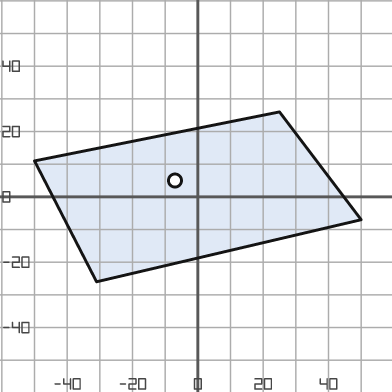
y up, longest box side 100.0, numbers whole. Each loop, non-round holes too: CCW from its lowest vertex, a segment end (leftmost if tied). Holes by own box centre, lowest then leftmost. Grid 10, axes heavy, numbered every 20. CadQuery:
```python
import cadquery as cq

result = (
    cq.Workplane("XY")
    .moveTo(-31.0, -26.0)
    .lineTo(50.0, -7.0)
    .lineTo(25.0, 26.0)
    .lineTo(-50.0, 11.0)
    .close()
    .moveTo(-7.0, 5.0)
    .circle(2.0)
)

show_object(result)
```